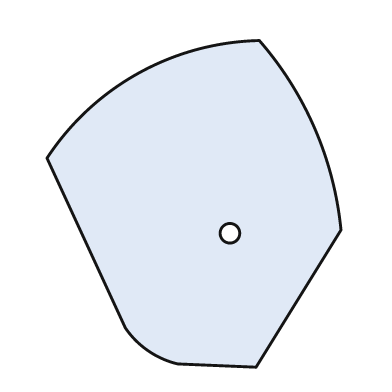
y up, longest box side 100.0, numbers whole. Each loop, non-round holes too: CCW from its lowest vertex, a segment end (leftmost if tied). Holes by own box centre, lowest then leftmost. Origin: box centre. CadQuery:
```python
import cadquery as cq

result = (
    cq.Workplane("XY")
    .moveTo(19.0, -50.0)
    .lineTo(45.0, -8.0)
    .threePointArc((37.0, 23.0), (20.0, 50.0))
    .threePointArc((-17.0, 40.0), (-45.0, 14.0))
    .lineTo(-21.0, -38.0)
    .threePointArc((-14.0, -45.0), (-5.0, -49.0))
    .close()
    .moveTo(11.0, -9.0)
    .circle(3.0)
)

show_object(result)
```